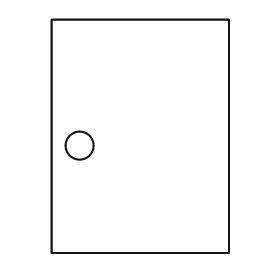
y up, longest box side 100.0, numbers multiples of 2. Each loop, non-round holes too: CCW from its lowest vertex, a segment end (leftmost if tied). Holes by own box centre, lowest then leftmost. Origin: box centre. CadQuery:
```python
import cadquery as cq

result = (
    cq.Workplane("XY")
    .moveTo(-38.0, -50.0)
    .lineTo(38.0, -50.0)
    .lineTo(38.0, 50.0)
    .lineTo(-38.0, 50.0)
    .close()
    .moveTo(-26.0, -4.0)
    .circle(6.0)
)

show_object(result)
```